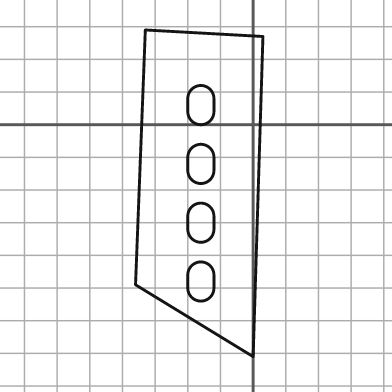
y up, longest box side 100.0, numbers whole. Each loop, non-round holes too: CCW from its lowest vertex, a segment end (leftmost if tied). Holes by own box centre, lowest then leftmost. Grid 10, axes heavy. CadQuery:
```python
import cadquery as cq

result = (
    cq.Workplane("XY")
    .moveTo(0.0, -71.0)
    .lineTo(3.0, 27.0)
    .lineTo(-33.0, 29.0)
    .lineTo(-36.0, -49.0)
    .close()
    .moveTo(-20.0, -50.0)
    .threePointArc((-16.0, -54.0), (-12.0, -50.0))
    .lineTo(-12.0, -46.0)
    .threePointArc((-16.0, -42.0), (-20.0, -46.0))
    .close()
    .moveTo(-20.0, -32.0)
    .threePointArc((-16.0, -36.0), (-12.0, -32.0))
    .lineTo(-12.0, -28.0)
    .threePointArc((-16.0, -24.0), (-20.0, -28.0))
    .close()
    .moveTo(-20.0, -14.0)
    .threePointArc((-16.0, -18.0), (-12.0, -14.0))
    .lineTo(-12.0, -10.0)
    .threePointArc((-16.0, -6.0), (-20.0, -10.0))
    .close()
    .moveTo(-20.0, 4.0)
    .threePointArc((-16.0, 0.0), (-12.0, 4.0))
    .lineTo(-12.0, 8.0)
    .threePointArc((-16.0, 12.0), (-20.0, 8.0))
    .close()
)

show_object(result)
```